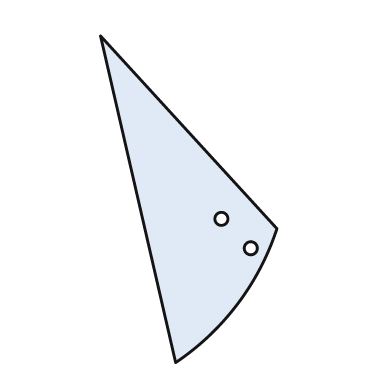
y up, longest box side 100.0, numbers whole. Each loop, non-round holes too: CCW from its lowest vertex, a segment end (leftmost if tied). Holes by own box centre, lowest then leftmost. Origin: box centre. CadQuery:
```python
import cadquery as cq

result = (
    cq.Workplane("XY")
    .moveTo(-4.0, -50.0)
    .threePointArc((15.0, -32.0), (27.0, -9.0))
    .lineTo(-27.0, 50.0)
    .close()
    .moveTo(19.0, -15.0)
    .circle(2.0)
    .moveTo(10.0, -6.0)
    .circle(2.0)
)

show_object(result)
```